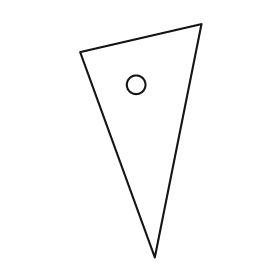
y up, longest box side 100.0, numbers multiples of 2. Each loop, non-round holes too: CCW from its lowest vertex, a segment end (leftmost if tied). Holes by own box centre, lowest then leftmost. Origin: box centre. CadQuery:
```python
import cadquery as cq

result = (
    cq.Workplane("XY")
    .moveTo(6.0, -50.0)
    .lineTo(26.0, 50.0)
    .lineTo(-26.0, 38.0)
    .close()
    .moveTo(-2.0, 24.0)
    .circle(4.0)
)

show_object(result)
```